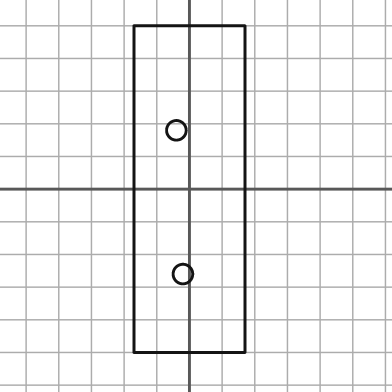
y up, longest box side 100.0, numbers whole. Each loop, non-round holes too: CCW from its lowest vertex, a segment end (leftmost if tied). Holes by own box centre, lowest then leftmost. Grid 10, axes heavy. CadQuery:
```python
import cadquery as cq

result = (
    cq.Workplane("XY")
    .moveTo(-17.0, -50.0)
    .lineTo(17.0, -50.0)
    .lineTo(17.0, 50.0)
    .lineTo(-17.0, 50.0)
    .close()
    .moveTo(-2.0, -26.0)
    .circle(3.0)
    .moveTo(-4.0, 18.0)
    .circle(3.0)
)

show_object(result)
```